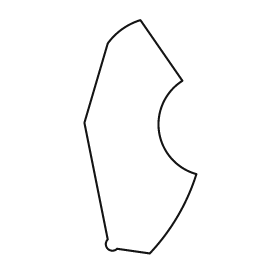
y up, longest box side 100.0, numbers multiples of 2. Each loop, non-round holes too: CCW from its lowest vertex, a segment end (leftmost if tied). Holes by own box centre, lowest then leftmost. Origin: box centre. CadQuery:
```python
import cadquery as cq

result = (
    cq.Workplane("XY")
    .moveTo(4.0, -50.0)
    .threePointArc((16.0, -34.0), (24.0, -16.0))
    .threePointArc((8.0, 2.0), (18.0, 24.0))
    .lineTo(0.0, 50.0)
    .threePointArc((-8.0, 46.0), (-14.0, 40.0))
    .lineTo(-24.0, 6.0)
    .lineTo(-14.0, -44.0)
    .threePointArc((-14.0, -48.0), (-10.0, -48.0))
    .close()
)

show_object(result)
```